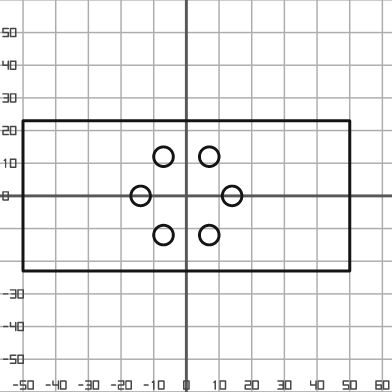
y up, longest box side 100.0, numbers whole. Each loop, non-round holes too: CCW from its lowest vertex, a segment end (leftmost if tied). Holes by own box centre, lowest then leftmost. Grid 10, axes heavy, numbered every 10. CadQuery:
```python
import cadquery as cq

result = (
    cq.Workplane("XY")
    .moveTo(-50.0, -23.0)
    .lineTo(50.0, -23.0)
    .lineTo(50.0, 23.0)
    .lineTo(-50.0, 23.0)
    .close()
    .moveTo(-7.0, -12.0)
    .circle(3.0)
    .moveTo(7.0, -12.0)
    .circle(3.0)
    .moveTo(-14.0, 0.0)
    .circle(3.0)
    .moveTo(14.0, 0.0)
    .circle(3.0)
    .moveTo(-7.0, 12.0)
    .circle(3.0)
    .moveTo(7.0, 12.0)
    .circle(3.0)
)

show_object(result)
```